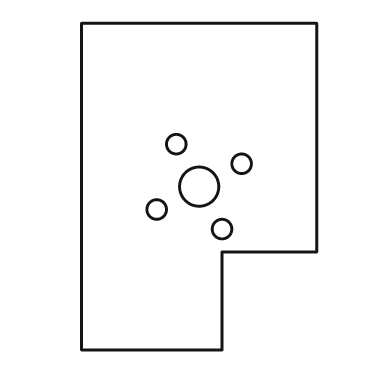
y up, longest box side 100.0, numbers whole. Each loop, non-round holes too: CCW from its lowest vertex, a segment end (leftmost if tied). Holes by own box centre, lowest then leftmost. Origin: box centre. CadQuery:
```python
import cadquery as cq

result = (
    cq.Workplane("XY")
    .moveTo(-36.0, -50.0)
    .lineTo(7.0, -50.0)
    .lineTo(7.0, -20.0)
    .lineTo(36.0, -20.0)
    .lineTo(36.0, 50.0)
    .lineTo(-36.0, 50.0)
    .close()
    .moveTo(7.0, -13.0)
    .circle(3.0)
    .moveTo(-13.0, -7.0)
    .circle(3.0)
    .moveTo(0.0, 0.0)
    .circle(6.0)
    .moveTo(13.0, 7.0)
    .circle(3.0)
    .moveTo(-7.0, 13.0)
    .circle(3.0)
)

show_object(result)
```